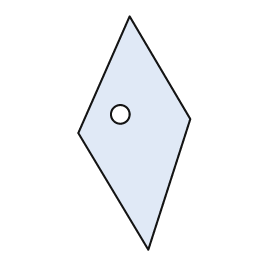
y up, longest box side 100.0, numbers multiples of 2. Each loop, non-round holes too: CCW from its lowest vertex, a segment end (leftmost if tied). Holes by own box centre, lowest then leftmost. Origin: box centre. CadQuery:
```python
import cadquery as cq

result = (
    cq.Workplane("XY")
    .moveTo(6.0, -50.0)
    .lineTo(24.0, 6.0)
    .lineTo(-2.0, 50.0)
    .lineTo(-24.0, 0.0)
    .close()
    .moveTo(-6.0, 8.0)
    .circle(4.0)
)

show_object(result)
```